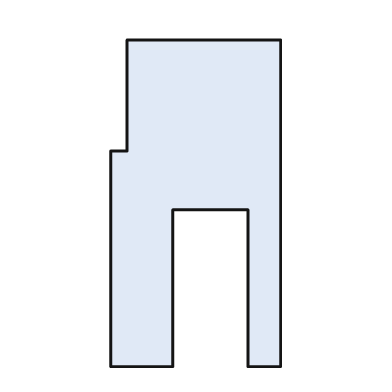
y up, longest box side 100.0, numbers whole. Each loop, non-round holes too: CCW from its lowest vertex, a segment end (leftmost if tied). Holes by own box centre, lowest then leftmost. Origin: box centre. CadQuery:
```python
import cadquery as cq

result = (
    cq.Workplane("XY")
    .moveTo(-26.0, -50.0)
    .lineTo(-7.0, -50.0)
    .lineTo(-7.0, -2.0)
    .lineTo(16.0, -2.0)
    .lineTo(16.0, -50.0)
    .lineTo(26.0, -50.0)
    .lineTo(26.0, 50.0)
    .lineTo(-21.0, 50.0)
    .lineTo(-21.0, 16.0)
    .lineTo(-26.0, 16.0)
    .close()
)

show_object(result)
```